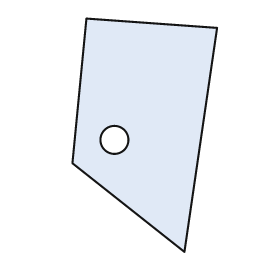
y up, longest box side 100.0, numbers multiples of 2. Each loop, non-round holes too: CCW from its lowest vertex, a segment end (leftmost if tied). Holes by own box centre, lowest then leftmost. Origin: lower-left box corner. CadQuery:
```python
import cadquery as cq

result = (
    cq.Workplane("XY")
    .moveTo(48.0, 0.0)
    .lineTo(62.0, 96.0)
    .lineTo(6.0, 100.0)
    .lineTo(0.0, 38.0)
    .close()
    .moveTo(18.0, 48.0)
    .circle(6.0)
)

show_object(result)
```